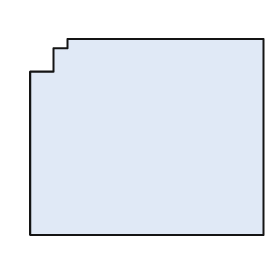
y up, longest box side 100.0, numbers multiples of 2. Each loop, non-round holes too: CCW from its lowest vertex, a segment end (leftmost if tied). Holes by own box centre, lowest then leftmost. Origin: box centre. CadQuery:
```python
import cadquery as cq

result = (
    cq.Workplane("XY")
    .moveTo(-50.0, -42.0)
    .lineTo(50.0, -42.0)
    .lineTo(50.0, 42.0)
    .lineTo(-34.0, 42.0)
    .lineTo(-34.0, 38.0)
    .lineTo(-40.0, 38.0)
    .lineTo(-40.0, 28.0)
    .lineTo(-50.0, 28.0)
    .close()
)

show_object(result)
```